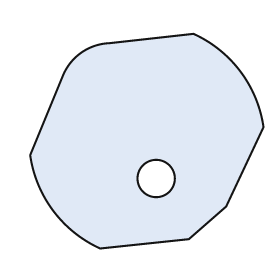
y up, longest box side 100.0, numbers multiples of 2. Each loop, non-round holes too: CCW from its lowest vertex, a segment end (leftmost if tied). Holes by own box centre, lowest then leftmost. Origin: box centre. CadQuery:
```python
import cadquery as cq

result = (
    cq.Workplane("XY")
    .moveTo(-20.0, -46.0)
    .lineTo(18.0, -42.0)
    .lineTo(34.0, -28.0)
    .lineTo(50.0, 6.0)
    .threePointArc((40.0, 30.0), (20.0, 46.0))
    .lineTo(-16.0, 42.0)
    .threePointArc((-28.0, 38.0), (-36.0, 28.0))
    .lineTo(-50.0, -6.0)
    .threePointArc((-40.0, -30.0), (-20.0, -46.0))
    .close()
    .moveTo(4.0, -16.0)
    .circle(8.0)
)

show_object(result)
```